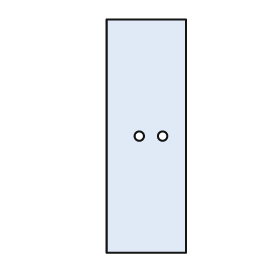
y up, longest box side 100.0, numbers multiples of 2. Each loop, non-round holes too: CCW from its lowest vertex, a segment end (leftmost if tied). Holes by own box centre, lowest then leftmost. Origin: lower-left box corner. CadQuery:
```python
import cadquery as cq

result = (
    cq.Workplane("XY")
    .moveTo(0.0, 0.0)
    .lineTo(34.0, 0.0)
    .lineTo(34.0, 100.0)
    .lineTo(0.0, 100.0)
    .close()
    .moveTo(14.0, 50.0)
    .circle(2.0)
    .moveTo(24.0, 50.0)
    .circle(2.0)
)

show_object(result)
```